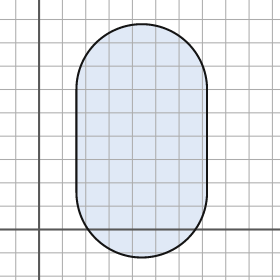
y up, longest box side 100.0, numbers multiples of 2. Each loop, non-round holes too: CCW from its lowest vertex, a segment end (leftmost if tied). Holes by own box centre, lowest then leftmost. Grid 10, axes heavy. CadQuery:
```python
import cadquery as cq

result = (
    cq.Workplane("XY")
    .moveTo(16.0, 16.0)
    .threePointArc((44.0, -12.0), (72.0, 16.0))
    .lineTo(72.0, 60.0)
    .threePointArc((44.0, 88.0), (16.0, 60.0))
    .close()
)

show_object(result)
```